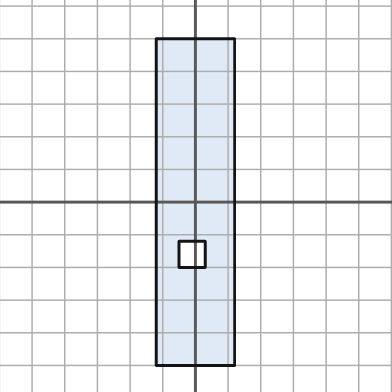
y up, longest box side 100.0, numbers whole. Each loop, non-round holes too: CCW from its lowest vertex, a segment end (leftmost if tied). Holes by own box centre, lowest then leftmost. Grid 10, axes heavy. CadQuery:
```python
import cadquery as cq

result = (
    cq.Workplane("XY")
    .moveTo(-12.0, -50.0)
    .lineTo(12.0, -50.0)
    .lineTo(12.0, 50.0)
    .lineTo(-12.0, 50.0)
    .close()
    .moveTo(-5.0, -20.0)
    .lineTo(3.0, -20.0)
    .lineTo(3.0, -12.0)
    .lineTo(-5.0, -12.0)
    .close()
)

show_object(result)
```